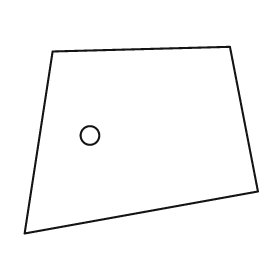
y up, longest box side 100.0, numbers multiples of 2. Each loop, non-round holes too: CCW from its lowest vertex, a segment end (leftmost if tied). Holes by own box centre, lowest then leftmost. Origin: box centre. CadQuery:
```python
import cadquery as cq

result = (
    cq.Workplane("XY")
    .moveTo(-50.0, -40.0)
    .lineTo(50.0, -22.0)
    .lineTo(38.0, 40.0)
    .lineTo(-38.0, 38.0)
    .close()
    .moveTo(-22.0, 2.0)
    .circle(4.0)
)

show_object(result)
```